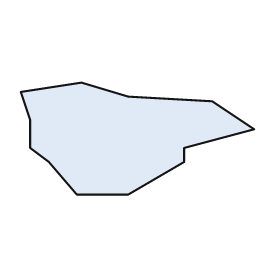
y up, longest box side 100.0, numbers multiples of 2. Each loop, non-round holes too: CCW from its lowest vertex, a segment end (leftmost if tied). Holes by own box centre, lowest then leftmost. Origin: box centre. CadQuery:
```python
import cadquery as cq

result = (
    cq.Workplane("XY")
    .moveTo(-26.0, -24.0)
    .lineTo(-4.0, -24.0)
    .lineTo(20.0, -10.0)
    .lineTo(20.0, -4.0)
    .lineTo(50.0, 4.0)
    .lineTo(32.0, 16.0)
    .lineTo(-4.0, 18.0)
    .lineTo(-24.0, 24.0)
    .lineTo(-50.0, 20.0)
    .lineTo(-46.0, 8.0)
    .lineTo(-46.0, -4.0)
    .lineTo(-38.0, -10.0)
    .close()
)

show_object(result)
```